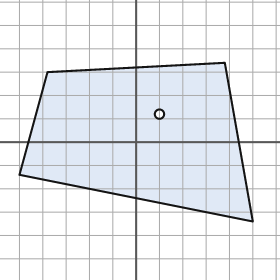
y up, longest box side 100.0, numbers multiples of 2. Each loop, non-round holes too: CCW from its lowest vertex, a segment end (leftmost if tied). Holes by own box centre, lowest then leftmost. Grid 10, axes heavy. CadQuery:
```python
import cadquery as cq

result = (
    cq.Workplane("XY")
    .moveTo(50.0, -34.0)
    .lineTo(38.0, 34.0)
    .lineTo(-38.0, 30.0)
    .lineTo(-50.0, -14.0)
    .close()
    .moveTo(10.0, 12.0)
    .circle(2.0)
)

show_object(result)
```